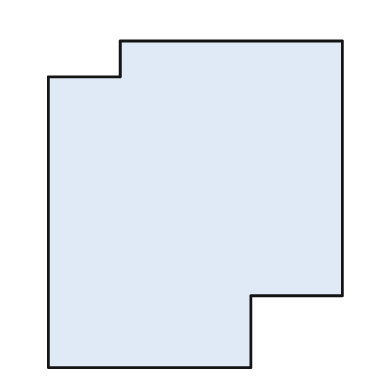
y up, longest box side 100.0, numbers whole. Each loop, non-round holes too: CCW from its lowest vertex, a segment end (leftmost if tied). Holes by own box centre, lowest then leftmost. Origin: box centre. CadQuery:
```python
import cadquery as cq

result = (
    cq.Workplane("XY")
    .moveTo(-45.0, -50.0)
    .lineTo(17.0, -50.0)
    .lineTo(17.0, -28.0)
    .lineTo(45.0, -28.0)
    .lineTo(45.0, 50.0)
    .lineTo(-23.0, 50.0)
    .lineTo(-23.0, 39.0)
    .lineTo(-45.0, 39.0)
    .close()
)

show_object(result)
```